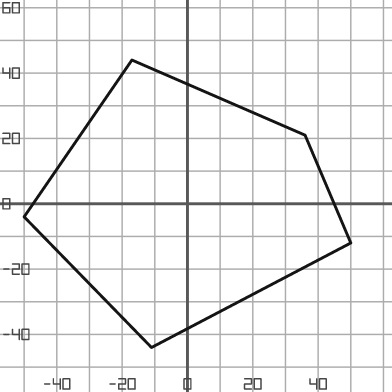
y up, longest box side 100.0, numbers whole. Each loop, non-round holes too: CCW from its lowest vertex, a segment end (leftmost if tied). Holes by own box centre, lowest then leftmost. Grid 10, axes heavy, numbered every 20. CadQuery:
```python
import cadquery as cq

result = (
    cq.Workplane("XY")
    .moveTo(-11.0, -44.0)
    .lineTo(50.0, -12.0)
    .lineTo(36.0, 21.0)
    .lineTo(-17.0, 44.0)
    .lineTo(-50.0, -4.0)
    .close()
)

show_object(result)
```